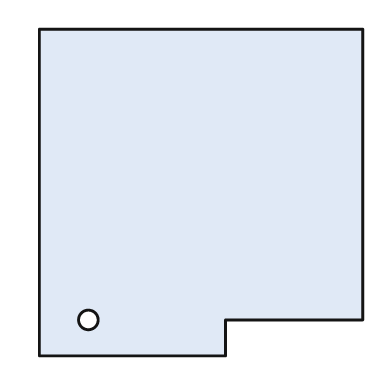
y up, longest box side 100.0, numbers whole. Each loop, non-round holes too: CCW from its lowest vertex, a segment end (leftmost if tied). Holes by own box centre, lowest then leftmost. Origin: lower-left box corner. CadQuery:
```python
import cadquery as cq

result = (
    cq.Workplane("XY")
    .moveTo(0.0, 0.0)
    .lineTo(57.0, 0.0)
    .lineTo(57.0, 11.0)
    .lineTo(99.0, 11.0)
    .lineTo(99.0, 100.0)
    .lineTo(0.0, 100.0)
    .close()
    .moveTo(15.0, 11.0)
    .circle(3.0)
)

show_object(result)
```